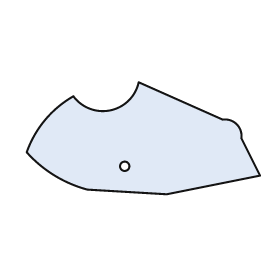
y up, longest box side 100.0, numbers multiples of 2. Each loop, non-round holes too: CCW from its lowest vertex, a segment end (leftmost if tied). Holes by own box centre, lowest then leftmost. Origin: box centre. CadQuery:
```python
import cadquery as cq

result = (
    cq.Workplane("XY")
    .moveTo(10.0, -24.0)
    .lineTo(50.0, -16.0)
    .lineTo(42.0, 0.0)
    .threePointArc((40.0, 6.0), (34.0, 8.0))
    .lineTo(-2.0, 24.0)
    .threePointArc((-14.0, 12.0), (-30.0, 18.0))
    .threePointArc((-42.0, 8.0), (-50.0, -6.0))
    .threePointArc((-38.0, -16.0), (-24.0, -22.0))
    .close()
    .moveTo(-8.0, -12.0)
    .circle(2.0)
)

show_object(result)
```